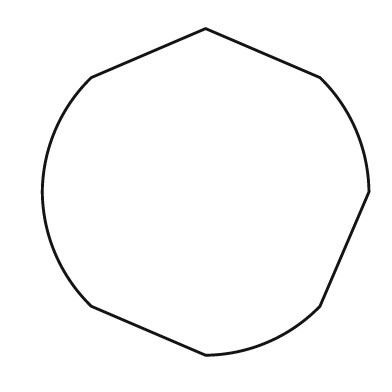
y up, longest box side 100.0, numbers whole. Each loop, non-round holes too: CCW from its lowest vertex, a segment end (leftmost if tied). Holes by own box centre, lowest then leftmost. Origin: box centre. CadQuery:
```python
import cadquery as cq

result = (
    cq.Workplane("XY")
    .moveTo(0.0, -50.0)
    .threePointArc((19.0, -46.0), (35.0, -35.0))
    .lineTo(50.0, 0.0)
    .threePointArc((46.0, 19.0), (35.0, 35.0))
    .lineTo(0.0, 50.0)
    .lineTo(-35.0, 35.0)
    .threePointArc((-46.0, 19.0), (-50.0, 0.0))
    .threePointArc((-46.0, -19.0), (-35.0, -35.0))
    .close()
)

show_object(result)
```